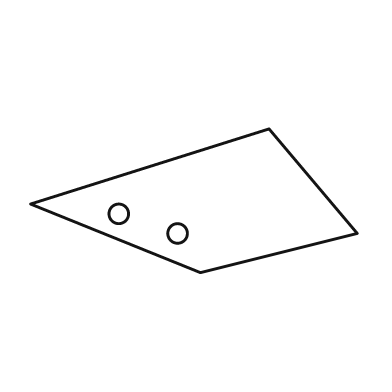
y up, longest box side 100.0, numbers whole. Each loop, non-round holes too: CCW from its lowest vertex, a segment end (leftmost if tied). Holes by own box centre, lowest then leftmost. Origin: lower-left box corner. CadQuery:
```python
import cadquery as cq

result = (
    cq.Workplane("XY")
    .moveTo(52.0, 0.0)
    .lineTo(100.0, 12.0)
    .lineTo(73.0, 44.0)
    .lineTo(0.0, 21.0)
    .close()
    .moveTo(45.0, 12.0)
    .circle(3.0)
    .moveTo(27.0, 18.0)
    .circle(3.0)
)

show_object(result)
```